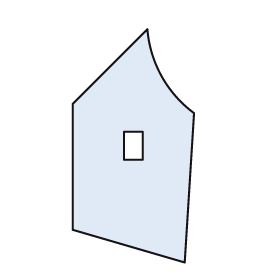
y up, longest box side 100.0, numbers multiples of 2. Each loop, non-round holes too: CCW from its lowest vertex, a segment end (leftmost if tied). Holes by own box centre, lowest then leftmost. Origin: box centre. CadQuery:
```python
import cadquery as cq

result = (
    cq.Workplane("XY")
    .moveTo(22.0, -50.0)
    .lineTo(26.0, 14.0)
    .threePointArc((12.0, 30.0), (6.0, 50.0))
    .lineTo(-26.0, 18.0)
    .lineTo(-26.0, -36.0)
    .close()
    .moveTo(-4.0, -6.0)
    .lineTo(4.0, -6.0)
    .lineTo(4.0, 6.0)
    .lineTo(-4.0, 6.0)
    .close()
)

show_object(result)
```